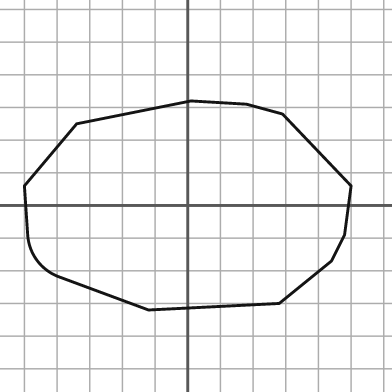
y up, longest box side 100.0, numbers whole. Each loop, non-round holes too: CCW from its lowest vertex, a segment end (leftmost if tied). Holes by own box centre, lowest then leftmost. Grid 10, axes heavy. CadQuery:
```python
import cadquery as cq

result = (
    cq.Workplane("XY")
    .moveTo(-12.0, -32.0)
    .lineTo(28.0, -30.0)
    .lineTo(44.0, -17.0)
    .lineTo(48.0, -9.0)
    .lineTo(50.0, 6.0)
    .lineTo(29.0, 28.0)
    .lineTo(18.0, 31.0)
    .lineTo(1.0, 32.0)
    .lineTo(-34.0, 25.0)
    .lineTo(-50.0, 6.0)
    .lineTo(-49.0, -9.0)
    .threePointArc((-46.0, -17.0), (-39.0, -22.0))
    .close()
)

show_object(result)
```